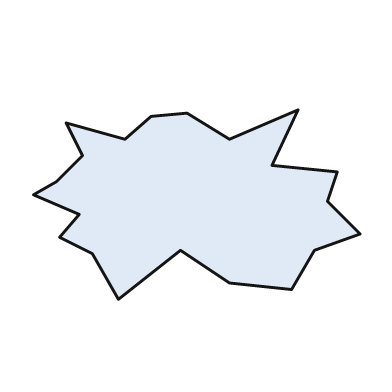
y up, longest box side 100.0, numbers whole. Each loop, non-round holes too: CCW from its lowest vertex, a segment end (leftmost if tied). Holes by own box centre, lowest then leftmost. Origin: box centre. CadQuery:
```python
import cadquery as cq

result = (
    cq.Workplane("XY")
    .moveTo(-24.0, -29.0)
    .lineTo(-5.0, -14.0)
    .lineTo(10.0, -24.0)
    .lineTo(29.0, -26.0)
    .lineTo(36.0, -14.0)
    .lineTo(50.0, -9.0)
    .lineTo(40.0, 1.0)
    .lineTo(43.0, 10.0)
    .lineTo(23.0, 12.0)
    .lineTo(31.0, 29.0)
    .lineTo(10.0, 20.0)
    .lineTo(-3.0, 28.0)
    .lineTo(-14.0, 27.0)
    .lineTo(-22.0, 20.0)
    .lineTo(-40.0, 25.0)
    .lineTo(-35.0, 15.0)
    .lineTo(-43.0, 7.0)
    .lineTo(-50.0, 3.0)
    .lineTo(-36.0, -3.0)
    .lineTo(-42.0, -10.0)
    .lineTo(-32.0, -15.0)
    .close()
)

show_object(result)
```